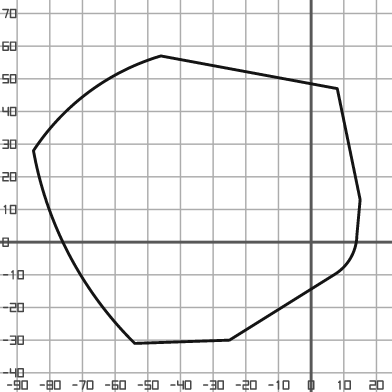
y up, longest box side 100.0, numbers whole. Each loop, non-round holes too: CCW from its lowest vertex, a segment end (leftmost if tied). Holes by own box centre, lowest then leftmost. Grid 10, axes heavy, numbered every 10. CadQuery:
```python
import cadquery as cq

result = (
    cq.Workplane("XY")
    .moveTo(-54.0, -31.0)
    .lineTo(-25.0, -30.0)
    .lineTo(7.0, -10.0)
    .threePointArc((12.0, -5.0), (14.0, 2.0))
    .lineTo(15.0, 13.0)
    .lineTo(8.0, 47.0)
    .lineTo(-46.0, 57.0)
    .threePointArc((-68.0, 46.0), (-85.0, 28.0))
    .threePointArc((-74.0, -4.0), (-54.0, -31.0))
    .close()
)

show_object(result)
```